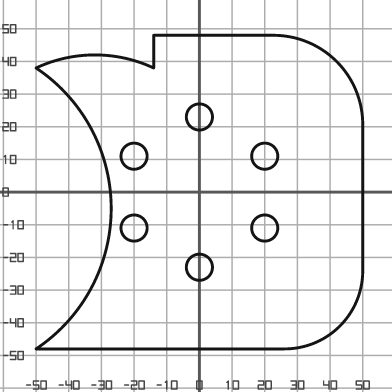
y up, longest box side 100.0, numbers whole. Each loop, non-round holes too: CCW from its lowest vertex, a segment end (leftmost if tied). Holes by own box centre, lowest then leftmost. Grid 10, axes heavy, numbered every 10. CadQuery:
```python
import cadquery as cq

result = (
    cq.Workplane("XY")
    .moveTo(-50.0, -48.0)
    .lineTo(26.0, -48.0)
    .threePointArc((43.0, -41.0), (50.0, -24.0))
    .lineTo(50.0, 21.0)
    .threePointArc((42.0, 40.0), (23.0, 48.0))
    .lineTo(-14.0, 48.0)
    .lineTo(-14.0, 38.0)
    .threePointArc((-32.0, 42.0), (-50.0, 38.0))
    .threePointArc((-27.0, -5.0), (-50.0, -48.0))
    .close()
    .moveTo(0.0, -23.0)
    .circle(4.0)
    .moveTo(-20.0, -11.0)
    .circle(4.0)
    .moveTo(20.0, -11.0)
    .circle(4.0)
    .moveTo(-20.0, 11.0)
    .circle(4.0)
    .moveTo(20.0, 11.0)
    .circle(4.0)
    .moveTo(0.0, 23.0)
    .circle(4.0)
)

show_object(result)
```